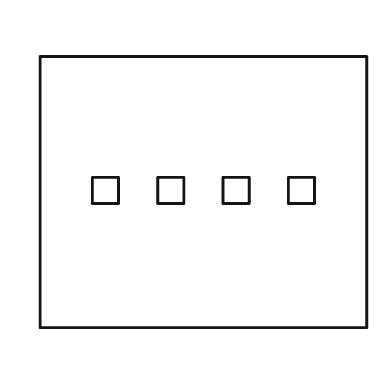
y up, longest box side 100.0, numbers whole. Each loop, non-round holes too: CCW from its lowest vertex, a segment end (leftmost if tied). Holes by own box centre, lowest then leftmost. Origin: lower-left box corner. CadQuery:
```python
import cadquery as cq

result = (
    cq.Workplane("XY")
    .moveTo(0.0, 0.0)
    .lineTo(100.0, 0.0)
    .lineTo(100.0, 83.0)
    .lineTo(0.0, 83.0)
    .close()
    .moveTo(16.0, 38.0)
    .lineTo(24.0, 38.0)
    .lineTo(24.0, 46.0)
    .lineTo(16.0, 46.0)
    .close()
    .moveTo(36.0, 38.0)
    .lineTo(44.0, 38.0)
    .lineTo(44.0, 46.0)
    .lineTo(36.0, 46.0)
    .close()
    .moveTo(56.0, 38.0)
    .lineTo(64.0, 38.0)
    .lineTo(64.0, 46.0)
    .lineTo(56.0, 46.0)
    .close()
    .moveTo(76.0, 38.0)
    .lineTo(84.0, 38.0)
    .lineTo(84.0, 46.0)
    .lineTo(76.0, 46.0)
    .close()
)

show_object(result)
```